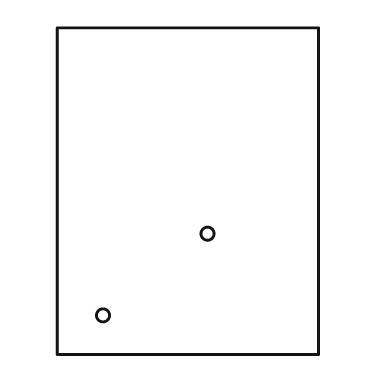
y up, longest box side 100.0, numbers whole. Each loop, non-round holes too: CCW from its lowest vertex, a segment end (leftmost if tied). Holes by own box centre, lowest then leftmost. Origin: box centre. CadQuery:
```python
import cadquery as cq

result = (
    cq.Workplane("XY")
    .moveTo(-40.0, -50.0)
    .lineTo(40.0, -50.0)
    .lineTo(40.0, 50.0)
    .lineTo(-40.0, 50.0)
    .close()
    .moveTo(-26.0, -38.0)
    .circle(2.0)
    .moveTo(6.0, -13.0)
    .circle(2.0)
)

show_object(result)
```